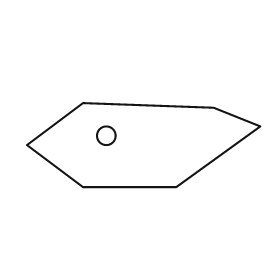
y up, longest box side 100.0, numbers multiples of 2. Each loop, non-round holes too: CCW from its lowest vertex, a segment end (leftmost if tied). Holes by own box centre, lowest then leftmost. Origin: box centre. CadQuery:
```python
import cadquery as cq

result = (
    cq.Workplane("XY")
    .moveTo(-26.0, -18.0)
    .lineTo(14.0, -18.0)
    .lineTo(50.0, 8.0)
    .lineTo(30.0, 16.0)
    .lineTo(-26.0, 18.0)
    .lineTo(-50.0, 0.0)
    .close()
    .moveTo(-16.0, 4.0)
    .circle(4.0)
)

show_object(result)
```